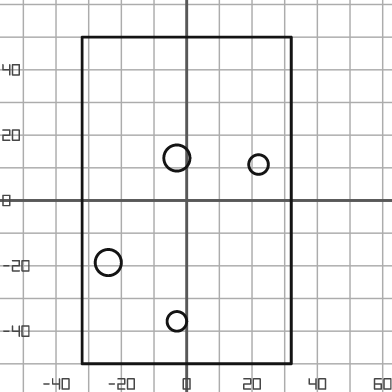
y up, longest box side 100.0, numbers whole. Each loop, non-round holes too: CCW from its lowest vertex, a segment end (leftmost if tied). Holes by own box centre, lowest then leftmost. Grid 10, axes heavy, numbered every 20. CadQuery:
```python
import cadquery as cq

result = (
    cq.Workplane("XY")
    .moveTo(-32.0, -50.0)
    .lineTo(32.0, -50.0)
    .lineTo(32.0, 50.0)
    .lineTo(-32.0, 50.0)
    .close()
    .moveTo(-3.0, -37.0)
    .circle(3.0)
    .moveTo(-24.0, -19.0)
    .circle(4.0)
    .moveTo(22.0, 11.0)
    .circle(3.0)
    .moveTo(-3.0, 13.0)
    .circle(4.0)
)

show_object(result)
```